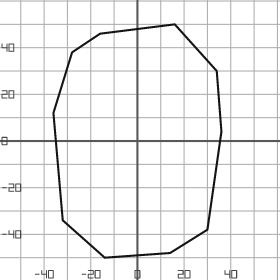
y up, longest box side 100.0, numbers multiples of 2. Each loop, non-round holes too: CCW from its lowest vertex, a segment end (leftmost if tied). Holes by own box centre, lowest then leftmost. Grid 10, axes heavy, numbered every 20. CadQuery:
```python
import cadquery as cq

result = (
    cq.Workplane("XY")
    .moveTo(-14.0, -50.0)
    .lineTo(14.0, -48.0)
    .lineTo(30.0, -38.0)
    .lineTo(36.0, 4.0)
    .lineTo(34.0, 30.0)
    .lineTo(16.0, 50.0)
    .lineTo(-16.0, 46.0)
    .lineTo(-28.0, 38.0)
    .lineTo(-36.0, 12.0)
    .lineTo(-32.0, -34.0)
    .close()
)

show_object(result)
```